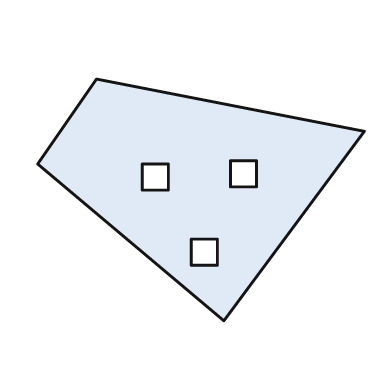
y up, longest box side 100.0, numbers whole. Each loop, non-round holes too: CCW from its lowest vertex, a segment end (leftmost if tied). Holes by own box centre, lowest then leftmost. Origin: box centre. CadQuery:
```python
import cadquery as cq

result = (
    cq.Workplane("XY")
    .moveTo(7.0, -37.0)
    .lineTo(50.0, 21.0)
    .lineTo(-32.0, 37.0)
    .lineTo(-50.0, 11.0)
    .close()
    .moveTo(-3.0, -20.0)
    .lineTo(5.0, -20.0)
    .lineTo(5.0, -12.0)
    .lineTo(-3.0, -12.0)
    .close()
    .moveTo(-18.0, 3.0)
    .lineTo(-10.0, 3.0)
    .lineTo(-10.0, 11.0)
    .lineTo(-18.0, 11.0)
    .close()
    .moveTo(9.0, 4.0)
    .lineTo(17.0, 4.0)
    .lineTo(17.0, 12.0)
    .lineTo(9.0, 12.0)
    .close()
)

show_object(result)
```